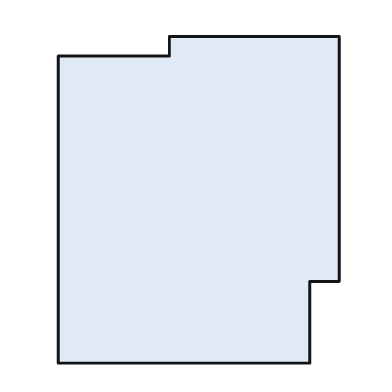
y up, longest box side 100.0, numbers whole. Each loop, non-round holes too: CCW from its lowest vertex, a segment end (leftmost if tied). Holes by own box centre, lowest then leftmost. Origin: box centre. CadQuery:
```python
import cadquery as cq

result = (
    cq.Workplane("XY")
    .moveTo(-43.0, -50.0)
    .lineTo(34.0, -50.0)
    .lineTo(34.0, -25.0)
    .lineTo(43.0, -25.0)
    .lineTo(43.0, 50.0)
    .lineTo(-9.0, 50.0)
    .lineTo(-9.0, 44.0)
    .lineTo(-43.0, 44.0)
    .close()
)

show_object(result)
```